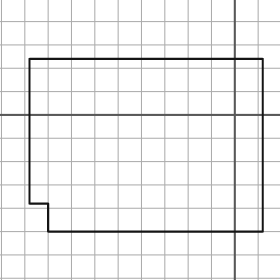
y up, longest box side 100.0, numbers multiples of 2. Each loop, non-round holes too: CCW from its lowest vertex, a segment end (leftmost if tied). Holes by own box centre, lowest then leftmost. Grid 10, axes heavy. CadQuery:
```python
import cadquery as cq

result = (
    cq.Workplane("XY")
    .moveTo(-80.0, -50.0)
    .lineTo(12.0, -50.0)
    .lineTo(12.0, 24.0)
    .lineTo(-88.0, 24.0)
    .lineTo(-88.0, -38.0)
    .lineTo(-80.0, -38.0)
    .close()
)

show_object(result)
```